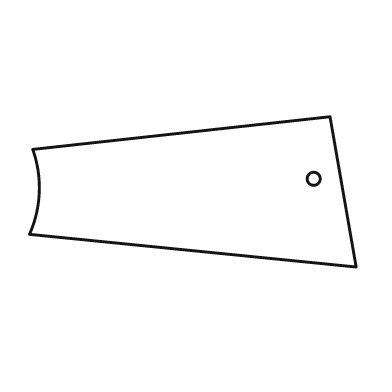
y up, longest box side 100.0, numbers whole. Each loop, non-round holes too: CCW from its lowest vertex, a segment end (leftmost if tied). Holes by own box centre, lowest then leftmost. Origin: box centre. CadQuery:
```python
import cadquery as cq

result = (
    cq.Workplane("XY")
    .moveTo(50.0, -23.0)
    .lineTo(42.0, 23.0)
    .lineTo(-49.0, 13.0)
    .threePointArc((-47.0, 0.0), (-50.0, -13.0))
    .close()
    .moveTo(37.0, 4.0)
    .circle(2.0)
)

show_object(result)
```